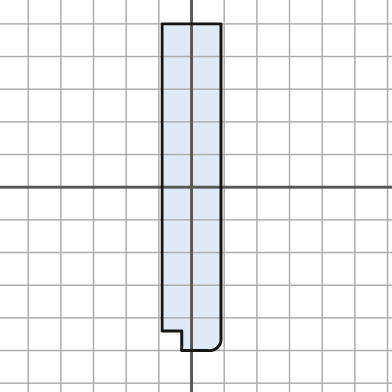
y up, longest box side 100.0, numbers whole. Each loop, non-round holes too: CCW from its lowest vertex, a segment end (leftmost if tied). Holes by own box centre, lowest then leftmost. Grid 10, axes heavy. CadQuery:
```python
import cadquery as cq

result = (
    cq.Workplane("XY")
    .moveTo(-3.0, -50.0)
    .lineTo(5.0, -50.0)
    .threePointArc((8.0, -49.0), (9.0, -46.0))
    .lineTo(9.0, 50.0)
    .lineTo(-9.0, 50.0)
    .lineTo(-9.0, -44.0)
    .lineTo(-3.0, -44.0)
    .close()
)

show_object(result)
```